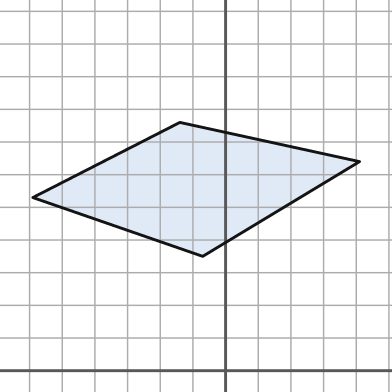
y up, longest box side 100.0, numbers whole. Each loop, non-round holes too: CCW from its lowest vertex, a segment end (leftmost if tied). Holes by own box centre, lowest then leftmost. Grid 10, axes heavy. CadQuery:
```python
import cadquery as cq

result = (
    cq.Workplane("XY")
    .moveTo(-7.0, 35.0)
    .lineTo(41.0, 64.0)
    .lineTo(-14.0, 76.0)
    .lineTo(-59.0, 53.0)
    .close()
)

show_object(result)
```